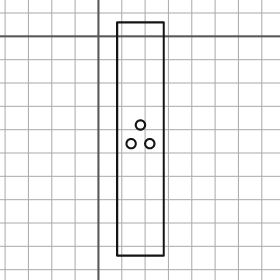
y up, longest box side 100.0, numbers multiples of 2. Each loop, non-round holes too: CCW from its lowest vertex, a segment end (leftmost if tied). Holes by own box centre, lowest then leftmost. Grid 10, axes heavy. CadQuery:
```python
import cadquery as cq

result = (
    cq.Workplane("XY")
    .moveTo(8.0, -94.0)
    .lineTo(28.0, -94.0)
    .lineTo(28.0, 6.0)
    .lineTo(8.0, 6.0)
    .close()
    .moveTo(14.0, -46.0)
    .circle(2.0)
    .moveTo(22.0, -46.0)
    .circle(2.0)
    .moveTo(18.0, -38.0)
    .circle(2.0)
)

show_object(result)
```